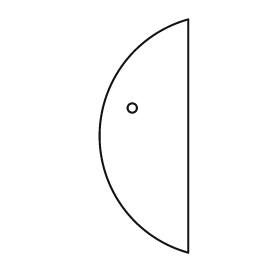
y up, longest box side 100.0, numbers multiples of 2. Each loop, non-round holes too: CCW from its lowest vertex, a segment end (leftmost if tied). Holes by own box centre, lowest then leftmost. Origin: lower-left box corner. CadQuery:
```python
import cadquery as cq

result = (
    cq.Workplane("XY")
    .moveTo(38.0, 0.0)
    .lineTo(38.0, 100.0)
    .threePointArc((0.0, 50.0), (38.0, 0.0))
    .close()
    .moveTo(14.0, 62.0)
    .circle(2.0)
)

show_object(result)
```